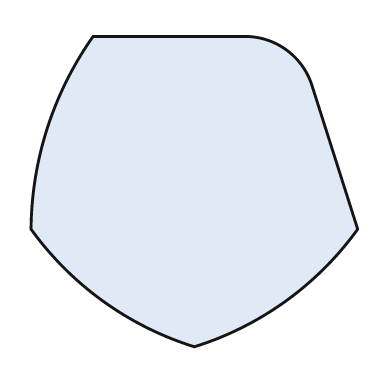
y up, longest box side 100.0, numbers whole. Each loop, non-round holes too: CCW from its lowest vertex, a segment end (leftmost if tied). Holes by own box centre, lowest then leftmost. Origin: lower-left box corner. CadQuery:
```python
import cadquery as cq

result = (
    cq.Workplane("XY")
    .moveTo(50.0, 0.0)
    .threePointArc((78.0, 14.0), (100.0, 36.0))
    .lineTo(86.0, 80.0)
    .threePointArc((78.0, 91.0), (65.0, 95.0))
    .lineTo(19.0, 95.0)
    .threePointArc((5.0, 67.0), (0.0, 36.0))
    .threePointArc((22.0, 14.0), (50.0, 0.0))
    .close()
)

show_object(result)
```